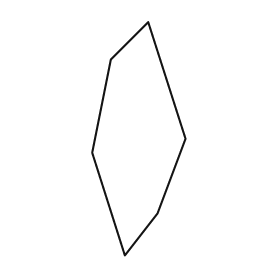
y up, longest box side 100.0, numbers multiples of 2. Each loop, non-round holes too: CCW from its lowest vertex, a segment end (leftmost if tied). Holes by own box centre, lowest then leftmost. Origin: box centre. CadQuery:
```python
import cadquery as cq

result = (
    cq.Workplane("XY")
    .moveTo(-6.0, -50.0)
    .lineTo(8.0, -32.0)
    .lineTo(20.0, 0.0)
    .lineTo(4.0, 50.0)
    .lineTo(-12.0, 34.0)
    .lineTo(-20.0, -6.0)
    .close()
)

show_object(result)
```